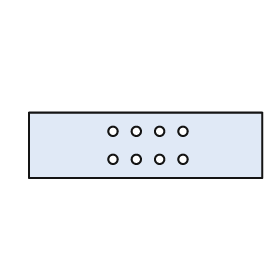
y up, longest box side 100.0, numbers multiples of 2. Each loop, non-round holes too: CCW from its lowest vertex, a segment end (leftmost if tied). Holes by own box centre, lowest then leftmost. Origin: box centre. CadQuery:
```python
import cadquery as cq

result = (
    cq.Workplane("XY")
    .moveTo(-50.0, -14.0)
    .lineTo(50.0, -14.0)
    .lineTo(50.0, 14.0)
    .lineTo(-50.0, 14.0)
    .close()
    .moveTo(-14.0, -6.0)
    .circle(2.0)
    .moveTo(-4.0, -6.0)
    .circle(2.0)
    .moveTo(6.0, -6.0)
    .circle(2.0)
    .moveTo(16.0, -6.0)
    .circle(2.0)
    .moveTo(-14.0, 6.0)
    .circle(2.0)
    .moveTo(-4.0, 6.0)
    .circle(2.0)
    .moveTo(6.0, 6.0)
    .circle(2.0)
    .moveTo(16.0, 6.0)
    .circle(2.0)
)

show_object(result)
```